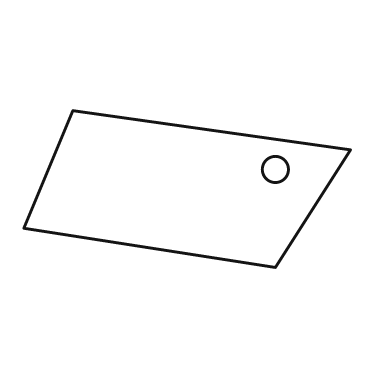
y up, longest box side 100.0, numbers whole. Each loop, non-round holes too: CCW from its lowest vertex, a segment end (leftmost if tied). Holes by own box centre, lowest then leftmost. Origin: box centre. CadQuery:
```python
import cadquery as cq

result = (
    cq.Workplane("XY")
    .moveTo(27.0, -24.0)
    .lineTo(50.0, 12.0)
    .lineTo(-35.0, 24.0)
    .lineTo(-50.0, -12.0)
    .close()
    .moveTo(27.0, 6.0)
    .circle(4.0)
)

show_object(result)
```